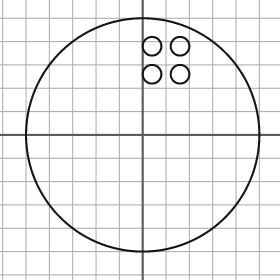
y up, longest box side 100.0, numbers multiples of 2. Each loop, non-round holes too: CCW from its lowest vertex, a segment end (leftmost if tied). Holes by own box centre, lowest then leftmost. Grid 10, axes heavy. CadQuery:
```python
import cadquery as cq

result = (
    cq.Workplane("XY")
    .moveTo(0.0, 0.0)
    .circle(50.0)
    .moveTo(4.0, 26.0)
    .circle(4.0)
    .moveTo(16.0, 26.0)
    .circle(4.0)
    .moveTo(4.0, 38.0)
    .circle(4.0)
    .moveTo(16.0, 38.0)
    .circle(4.0)
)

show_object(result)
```